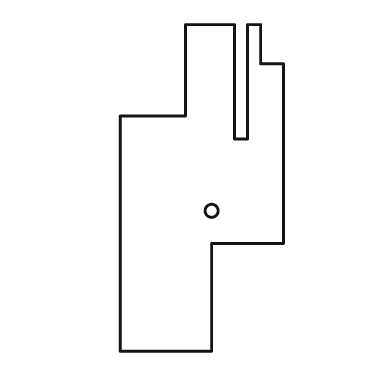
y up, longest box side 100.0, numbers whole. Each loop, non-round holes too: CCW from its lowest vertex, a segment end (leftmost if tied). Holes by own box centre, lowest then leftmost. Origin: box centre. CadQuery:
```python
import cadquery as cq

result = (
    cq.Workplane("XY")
    .moveTo(-25.0, -50.0)
    .lineTo(3.0, -50.0)
    .lineTo(3.0, -17.0)
    .lineTo(25.0, -17.0)
    .lineTo(25.0, 38.0)
    .lineTo(18.0, 38.0)
    .lineTo(18.0, 50.0)
    .lineTo(14.0, 50.0)
    .lineTo(14.0, 15.0)
    .lineTo(10.0, 15.0)
    .lineTo(10.0, 50.0)
    .lineTo(-5.0, 50.0)
    .lineTo(-5.0, 22.0)
    .lineTo(-25.0, 22.0)
    .close()
    .moveTo(3.0, -7.0)
    .circle(2.0)
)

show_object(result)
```